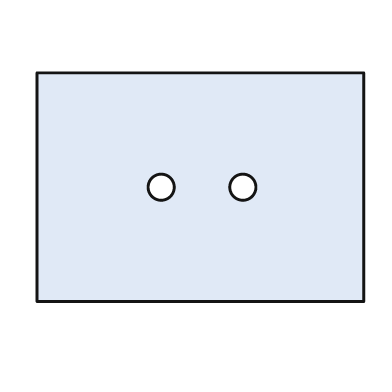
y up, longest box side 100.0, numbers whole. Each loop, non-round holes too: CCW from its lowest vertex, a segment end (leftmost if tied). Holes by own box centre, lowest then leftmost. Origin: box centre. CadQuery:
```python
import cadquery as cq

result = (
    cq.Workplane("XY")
    .moveTo(-50.0, -35.0)
    .lineTo(50.0, -35.0)
    .lineTo(50.0, 35.0)
    .lineTo(-50.0, 35.0)
    .close()
    .moveTo(-12.0, 0.0)
    .circle(4.0)
    .moveTo(13.0, 0.0)
    .circle(4.0)
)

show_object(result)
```